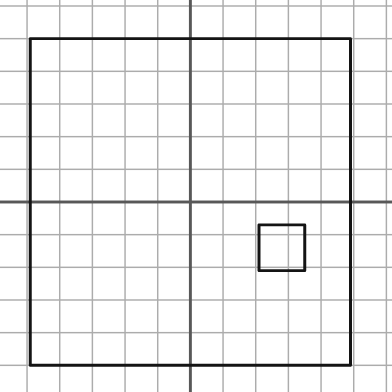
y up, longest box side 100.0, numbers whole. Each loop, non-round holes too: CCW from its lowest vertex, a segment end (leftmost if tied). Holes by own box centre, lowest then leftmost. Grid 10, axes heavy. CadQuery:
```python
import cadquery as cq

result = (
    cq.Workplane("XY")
    .moveTo(-49.0, -50.0)
    .lineTo(49.0, -50.0)
    .lineTo(49.0, 50.0)
    .lineTo(-49.0, 50.0)
    .close()
    .moveTo(21.0, -21.0)
    .lineTo(35.0, -21.0)
    .lineTo(35.0, -7.0)
    .lineTo(21.0, -7.0)
    .close()
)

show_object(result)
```